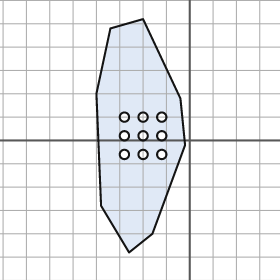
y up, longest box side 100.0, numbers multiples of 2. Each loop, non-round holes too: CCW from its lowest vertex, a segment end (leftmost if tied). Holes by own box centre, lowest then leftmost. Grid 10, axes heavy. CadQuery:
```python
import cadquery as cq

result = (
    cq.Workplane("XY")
    .moveTo(-26.0, -48.0)
    .lineTo(-16.0, -40.0)
    .lineTo(-2.0, -2.0)
    .lineTo(-4.0, 18.0)
    .lineTo(-20.0, 52.0)
    .lineTo(-34.0, 48.0)
    .lineTo(-40.0, 20.0)
    .lineTo(-38.0, -28.0)
    .close()
    .moveTo(-28.0, -6.0)
    .circle(2.0)
    .moveTo(-20.0, -6.0)
    .circle(2.0)
    .moveTo(-12.0, -6.0)
    .circle(2.0)
    .moveTo(-28.0, 2.0)
    .circle(2.0)
    .moveTo(-20.0, 2.0)
    .circle(2.0)
    .moveTo(-12.0, 2.0)
    .circle(2.0)
    .moveTo(-28.0, 10.0)
    .circle(2.0)
    .moveTo(-20.0, 10.0)
    .circle(2.0)
    .moveTo(-12.0, 10.0)
    .circle(2.0)
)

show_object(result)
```